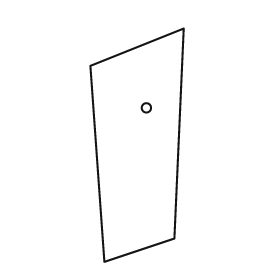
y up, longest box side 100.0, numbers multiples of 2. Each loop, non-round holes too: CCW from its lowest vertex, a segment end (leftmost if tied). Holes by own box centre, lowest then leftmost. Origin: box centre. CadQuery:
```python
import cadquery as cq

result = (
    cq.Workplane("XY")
    .moveTo(-14.0, -50.0)
    .lineTo(16.0, -40.0)
    .lineTo(20.0, 50.0)
    .lineTo(-20.0, 34.0)
    .close()
    .moveTo(4.0, 16.0)
    .circle(2.0)
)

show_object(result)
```